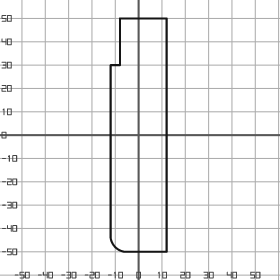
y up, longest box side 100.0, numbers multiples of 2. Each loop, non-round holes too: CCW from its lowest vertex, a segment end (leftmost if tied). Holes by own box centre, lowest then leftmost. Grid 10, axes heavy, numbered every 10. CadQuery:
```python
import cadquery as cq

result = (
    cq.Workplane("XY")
    .moveTo(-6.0, -50.0)
    .lineTo(12.0, -50.0)
    .lineTo(12.0, 50.0)
    .lineTo(-8.0, 50.0)
    .lineTo(-8.0, 30.0)
    .lineTo(-12.0, 30.0)
    .lineTo(-12.0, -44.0)
    .threePointArc((-10.0, -48.0), (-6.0, -50.0))
    .close()
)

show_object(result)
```